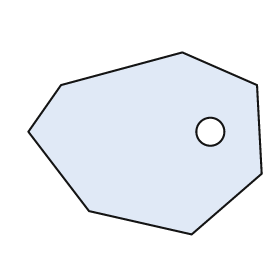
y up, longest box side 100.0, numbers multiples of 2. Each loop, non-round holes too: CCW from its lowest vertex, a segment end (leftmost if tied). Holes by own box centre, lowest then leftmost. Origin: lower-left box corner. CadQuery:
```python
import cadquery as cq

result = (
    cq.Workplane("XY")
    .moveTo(70.0, 0.0)
    .lineTo(100.0, 26.0)
    .lineTo(98.0, 64.0)
    .lineTo(66.0, 78.0)
    .lineTo(14.0, 64.0)
    .lineTo(0.0, 44.0)
    .lineTo(26.0, 10.0)
    .close()
    .moveTo(78.0, 44.0)
    .circle(6.0)
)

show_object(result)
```